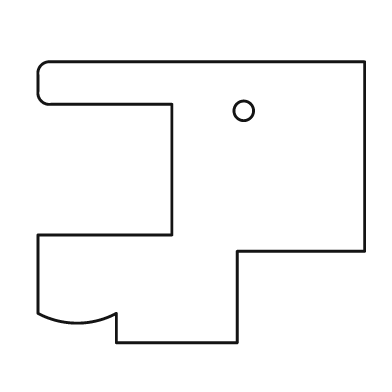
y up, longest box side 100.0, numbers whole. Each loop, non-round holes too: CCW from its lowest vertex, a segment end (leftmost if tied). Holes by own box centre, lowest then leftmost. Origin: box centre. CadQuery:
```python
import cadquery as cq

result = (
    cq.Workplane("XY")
    .moveTo(-26.0, -43.0)
    .lineTo(11.0, -43.0)
    .lineTo(11.0, -15.0)
    .lineTo(50.0, -15.0)
    .lineTo(50.0, 43.0)
    .lineTo(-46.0, 43.0)
    .threePointArc((-49.0, 42.0), (-50.0, 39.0))
    .lineTo(-50.0, 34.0)
    .threePointArc((-49.0, 31.0), (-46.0, 30.0))
    .lineTo(-9.0, 30.0)
    .lineTo(-9.0, -10.0)
    .lineTo(-50.0, -10.0)
    .lineTo(-50.0, -34.0)
    .threePointArc((-38.0, -37.0), (-26.0, -34.0))
    .close()
    .moveTo(13.0, 28.0)
    .circle(3.0)
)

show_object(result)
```